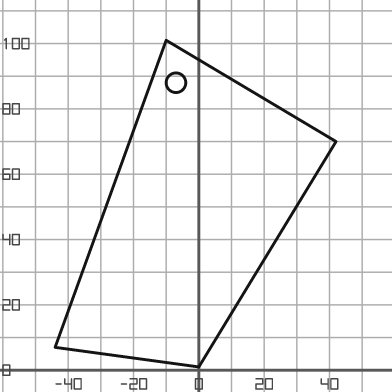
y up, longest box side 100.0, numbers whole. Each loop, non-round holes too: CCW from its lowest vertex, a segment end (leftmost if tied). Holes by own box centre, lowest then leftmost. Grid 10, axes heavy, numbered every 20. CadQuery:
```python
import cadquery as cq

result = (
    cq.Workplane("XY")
    .moveTo(0.0, 1.0)
    .lineTo(42.0, 70.0)
    .lineTo(-10.0, 101.0)
    .lineTo(-44.0, 7.0)
    .close()
    .moveTo(-7.0, 88.0)
    .circle(3.0)
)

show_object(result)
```